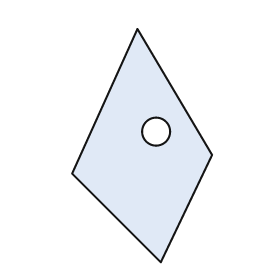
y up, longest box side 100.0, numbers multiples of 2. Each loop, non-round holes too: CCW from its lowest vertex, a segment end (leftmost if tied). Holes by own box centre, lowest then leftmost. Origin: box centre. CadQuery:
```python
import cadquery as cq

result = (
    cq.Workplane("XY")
    .moveTo(8.0, -50.0)
    .lineTo(30.0, -4.0)
    .lineTo(-2.0, 50.0)
    .lineTo(-30.0, -12.0)
    .close()
    .moveTo(6.0, 6.0)
    .circle(6.0)
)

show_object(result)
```